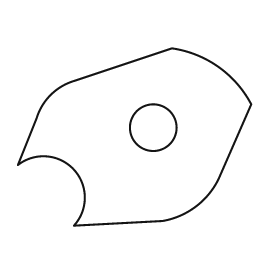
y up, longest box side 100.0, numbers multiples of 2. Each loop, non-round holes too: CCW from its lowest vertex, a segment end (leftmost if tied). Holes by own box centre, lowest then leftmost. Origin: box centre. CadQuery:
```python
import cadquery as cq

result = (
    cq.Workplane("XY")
    .moveTo(-26.0, -38.0)
    .lineTo(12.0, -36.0)
    .threePointArc((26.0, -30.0), (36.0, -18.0))
    .lineTo(50.0, 14.0)
    .threePointArc((36.0, 30.0), (16.0, 38.0))
    .lineTo(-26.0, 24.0)
    .threePointArc((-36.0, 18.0), (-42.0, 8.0))
    .lineTo(-50.0, -12.0)
    .threePointArc((-26.0, -14.0), (-26.0, -38.0))
    .close()
    .moveTo(8.0, 4.0)
    .circle(10.0)
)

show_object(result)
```